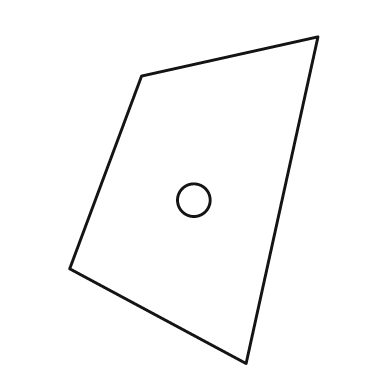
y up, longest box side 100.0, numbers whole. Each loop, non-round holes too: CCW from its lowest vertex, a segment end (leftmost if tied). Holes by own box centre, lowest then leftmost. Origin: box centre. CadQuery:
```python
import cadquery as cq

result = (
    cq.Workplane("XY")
    .moveTo(16.0, -50.0)
    .lineTo(38.0, 50.0)
    .lineTo(-16.0, 38.0)
    .lineTo(-38.0, -21.0)
    .close()
    .moveTo(0.0, 0.0)
    .circle(5.0)
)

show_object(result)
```